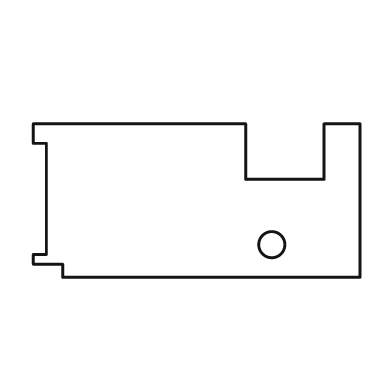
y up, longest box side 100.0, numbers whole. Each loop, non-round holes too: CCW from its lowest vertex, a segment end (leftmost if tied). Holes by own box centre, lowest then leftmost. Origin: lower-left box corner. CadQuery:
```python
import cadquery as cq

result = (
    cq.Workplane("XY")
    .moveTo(9.0, 0.0)
    .lineTo(100.0, 0.0)
    .lineTo(100.0, 47.0)
    .lineTo(89.0, 47.0)
    .lineTo(89.0, 30.0)
    .lineTo(65.0, 30.0)
    .lineTo(65.0, 47.0)
    .lineTo(0.0, 47.0)
    .lineTo(0.0, 41.0)
    .lineTo(4.0, 41.0)
    .lineTo(4.0, 7.0)
    .lineTo(0.0, 7.0)
    .lineTo(0.0, 4.0)
    .lineTo(9.0, 4.0)
    .close()
    .moveTo(73.0, 10.0)
    .circle(4.0)
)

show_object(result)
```